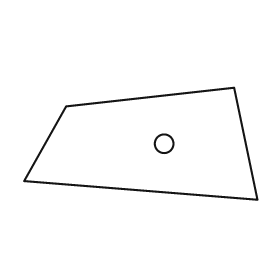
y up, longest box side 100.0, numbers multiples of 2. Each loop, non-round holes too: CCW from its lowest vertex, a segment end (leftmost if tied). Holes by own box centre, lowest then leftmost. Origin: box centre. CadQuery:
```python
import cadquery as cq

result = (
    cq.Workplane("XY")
    .moveTo(50.0, -24.0)
    .lineTo(40.0, 24.0)
    .lineTo(-32.0, 16.0)
    .lineTo(-50.0, -16.0)
    .close()
    .moveTo(10.0, 0.0)
    .circle(4.0)
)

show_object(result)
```